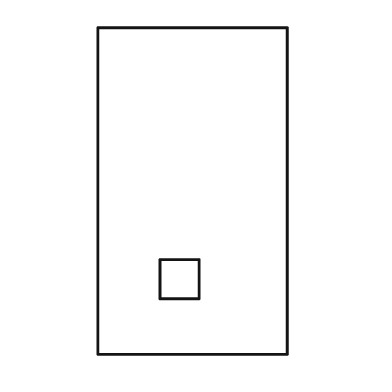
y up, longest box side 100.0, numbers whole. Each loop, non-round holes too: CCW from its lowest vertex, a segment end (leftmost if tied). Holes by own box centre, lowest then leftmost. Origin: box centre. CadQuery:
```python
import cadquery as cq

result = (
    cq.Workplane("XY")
    .moveTo(-29.0, -50.0)
    .lineTo(29.0, -50.0)
    .lineTo(29.0, 50.0)
    .lineTo(-29.0, 50.0)
    .close()
    .moveTo(-10.0, -33.0)
    .lineTo(2.0, -33.0)
    .lineTo(2.0, -21.0)
    .lineTo(-10.0, -21.0)
    .close()
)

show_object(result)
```